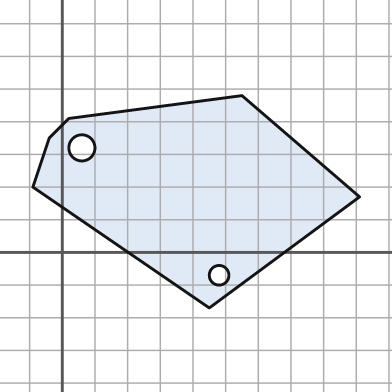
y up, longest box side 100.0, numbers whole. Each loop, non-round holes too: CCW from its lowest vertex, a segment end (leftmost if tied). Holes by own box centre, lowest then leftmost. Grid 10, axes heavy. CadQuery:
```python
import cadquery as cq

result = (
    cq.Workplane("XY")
    .moveTo(45.0, -17.0)
    .lineTo(91.0, 17.0)
    .lineTo(55.0, 48.0)
    .lineTo(2.0, 41.0)
    .lineTo(-4.0, 35.0)
    .lineTo(-9.0, 20.0)
    .close()
    .moveTo(48.0, -7.0)
    .circle(3.0)
    .moveTo(6.0, 32.0)
    .circle(4.0)
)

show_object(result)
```